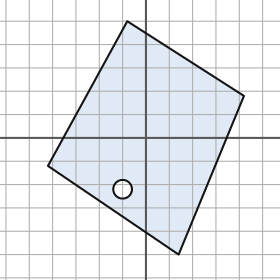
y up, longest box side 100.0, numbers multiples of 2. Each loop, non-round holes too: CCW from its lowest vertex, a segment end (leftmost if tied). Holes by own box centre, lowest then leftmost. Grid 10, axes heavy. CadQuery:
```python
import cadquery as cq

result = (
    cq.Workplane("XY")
    .moveTo(14.0, -50.0)
    .lineTo(42.0, 18.0)
    .lineTo(-8.0, 50.0)
    .lineTo(-42.0, -12.0)
    .close()
    .moveTo(-10.0, -22.0)
    .circle(4.0)
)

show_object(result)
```